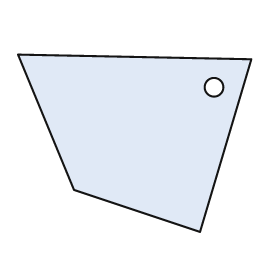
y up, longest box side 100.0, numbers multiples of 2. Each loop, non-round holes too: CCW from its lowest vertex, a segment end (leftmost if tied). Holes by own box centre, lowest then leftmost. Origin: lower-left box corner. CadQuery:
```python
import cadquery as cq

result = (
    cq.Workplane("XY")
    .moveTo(78.0, 0.0)
    .lineTo(100.0, 74.0)
    .lineTo(0.0, 76.0)
    .lineTo(24.0, 18.0)
    .close()
    .moveTo(84.0, 62.0)
    .circle(4.0)
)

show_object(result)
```